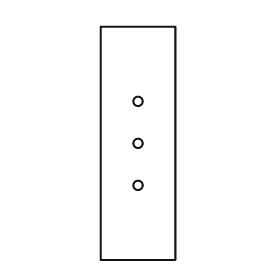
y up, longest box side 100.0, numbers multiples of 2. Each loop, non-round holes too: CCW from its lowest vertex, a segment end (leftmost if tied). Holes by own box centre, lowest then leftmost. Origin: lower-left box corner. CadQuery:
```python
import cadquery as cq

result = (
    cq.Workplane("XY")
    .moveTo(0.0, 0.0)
    .lineTo(32.0, 0.0)
    .lineTo(32.0, 100.0)
    .lineTo(0.0, 100.0)
    .close()
    .moveTo(16.0, 32.0)
    .circle(2.0)
    .moveTo(16.0, 50.0)
    .circle(2.0)
    .moveTo(16.0, 68.0)
    .circle(2.0)
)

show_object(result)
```